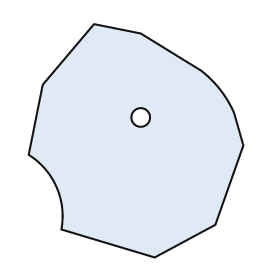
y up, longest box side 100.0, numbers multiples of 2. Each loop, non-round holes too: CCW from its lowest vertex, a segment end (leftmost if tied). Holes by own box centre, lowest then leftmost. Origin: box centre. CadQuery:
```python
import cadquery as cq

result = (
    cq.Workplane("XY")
    .moveTo(8.0, -50.0)
    .lineTo(34.0, -36.0)
    .lineTo(46.0, -2.0)
    .lineTo(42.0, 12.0)
    .threePointArc((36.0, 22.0), (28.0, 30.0))
    .lineTo(2.0, 46.0)
    .lineTo(-18.0, 50.0)
    .lineTo(-40.0, 24.0)
    .lineTo(-46.0, -6.0)
    .threePointArc((-34.0, -20.0), (-32.0, -38.0))
    .close()
    .moveTo(2.0, 10.0)
    .circle(4.0)
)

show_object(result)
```